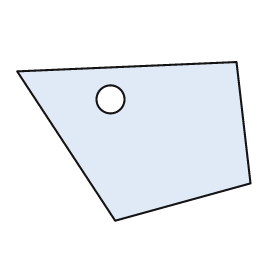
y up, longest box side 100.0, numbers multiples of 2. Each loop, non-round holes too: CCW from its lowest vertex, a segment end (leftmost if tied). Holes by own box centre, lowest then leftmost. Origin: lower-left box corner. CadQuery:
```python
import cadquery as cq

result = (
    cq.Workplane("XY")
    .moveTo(42.0, 0.0)
    .lineTo(100.0, 16.0)
    .lineTo(94.0, 68.0)
    .lineTo(0.0, 64.0)
    .close()
    .moveTo(40.0, 52.0)
    .circle(6.0)
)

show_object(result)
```